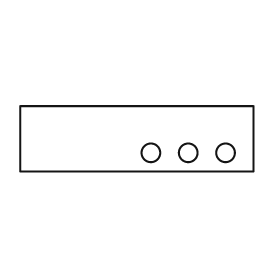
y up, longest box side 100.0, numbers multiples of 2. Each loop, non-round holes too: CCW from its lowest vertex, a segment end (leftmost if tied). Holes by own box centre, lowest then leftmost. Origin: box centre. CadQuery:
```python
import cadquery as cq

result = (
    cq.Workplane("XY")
    .moveTo(-50.0, -14.0)
    .lineTo(50.0, -14.0)
    .lineTo(50.0, 14.0)
    .lineTo(-50.0, 14.0)
    .close()
    .moveTo(6.0, -6.0)
    .circle(4.0)
    .moveTo(22.0, -6.0)
    .circle(4.0)
    .moveTo(38.0, -6.0)
    .circle(4.0)
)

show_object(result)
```